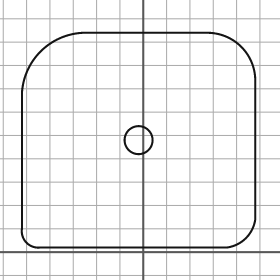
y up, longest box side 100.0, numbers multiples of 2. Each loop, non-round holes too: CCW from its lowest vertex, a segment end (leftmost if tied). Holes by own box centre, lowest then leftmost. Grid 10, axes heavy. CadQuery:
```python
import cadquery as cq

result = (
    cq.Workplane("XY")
    .moveTo(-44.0, 2.0)
    .lineTo(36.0, 2.0)
    .threePointArc((44.0, 6.0), (48.0, 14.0))
    .lineTo(48.0, 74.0)
    .threePointArc((42.0, 88.0), (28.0, 94.0))
    .lineTo(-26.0, 94.0)
    .threePointArc((-44.0, 86.0), (-52.0, 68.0))
    .lineTo(-52.0, 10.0)
    .threePointArc((-50.0, 4.0), (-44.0, 2.0))
    .close()
    .moveTo(-2.0, 48.0)
    .circle(6.0)
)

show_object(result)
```